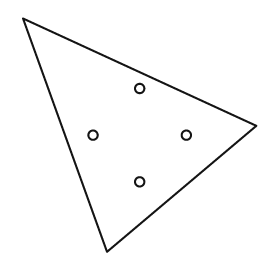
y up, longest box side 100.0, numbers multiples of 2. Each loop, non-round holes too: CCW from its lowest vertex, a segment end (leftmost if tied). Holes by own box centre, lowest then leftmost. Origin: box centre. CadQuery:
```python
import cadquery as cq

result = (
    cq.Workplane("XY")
    .moveTo(-14.0, -50.0)
    .lineTo(50.0, 4.0)
    .lineTo(-50.0, 50.0)
    .close()
    .moveTo(0.0, -20.0)
    .circle(2.0)
    .moveTo(-20.0, 0.0)
    .circle(2.0)
    .moveTo(20.0, 0.0)
    .circle(2.0)
    .moveTo(0.0, 20.0)
    .circle(2.0)
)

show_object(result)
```